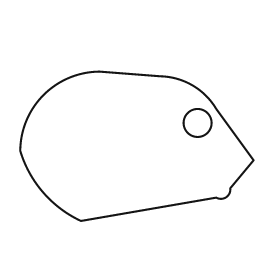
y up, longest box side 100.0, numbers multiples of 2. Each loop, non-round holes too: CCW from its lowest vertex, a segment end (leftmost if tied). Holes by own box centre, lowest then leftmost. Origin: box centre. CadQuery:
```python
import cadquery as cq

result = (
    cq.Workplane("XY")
    .moveTo(-24.0, -32.0)
    .lineTo(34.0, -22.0)
    .threePointArc((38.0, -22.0), (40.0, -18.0))
    .lineTo(50.0, -6.0)
    .lineTo(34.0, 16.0)
    .threePointArc((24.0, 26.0), (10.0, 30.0))
    .lineTo(-16.0, 32.0)
    .threePointArc((-40.0, 22.0), (-50.0, -2.0))
    .threePointArc((-40.0, -20.0), (-24.0, -32.0))
    .close()
    .moveTo(26.0, 10.0)
    .circle(6.0)
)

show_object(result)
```